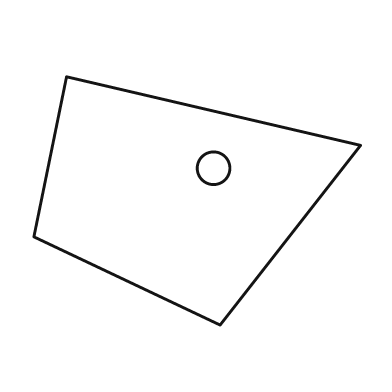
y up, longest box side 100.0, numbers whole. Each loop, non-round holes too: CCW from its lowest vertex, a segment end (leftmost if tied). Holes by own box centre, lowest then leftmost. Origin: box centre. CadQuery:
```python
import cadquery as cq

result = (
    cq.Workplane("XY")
    .moveTo(7.0, -38.0)
    .lineTo(50.0, 17.0)
    .lineTo(-40.0, 38.0)
    .lineTo(-50.0, -11.0)
    .close()
    .moveTo(5.0, 10.0)
    .circle(5.0)
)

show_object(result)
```